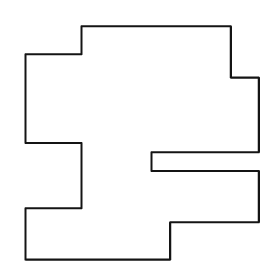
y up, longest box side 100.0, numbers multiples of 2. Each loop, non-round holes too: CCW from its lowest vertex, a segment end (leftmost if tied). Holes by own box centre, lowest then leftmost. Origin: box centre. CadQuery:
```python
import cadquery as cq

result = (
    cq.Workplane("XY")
    .moveTo(-50.0, -50.0)
    .lineTo(12.0, -50.0)
    .lineTo(12.0, -34.0)
    .lineTo(50.0, -34.0)
    .lineTo(50.0, -12.0)
    .lineTo(4.0, -12.0)
    .lineTo(4.0, -4.0)
    .lineTo(50.0, -4.0)
    .lineTo(50.0, 28.0)
    .lineTo(38.0, 28.0)
    .lineTo(38.0, 50.0)
    .lineTo(-26.0, 50.0)
    .lineTo(-26.0, 38.0)
    .lineTo(-50.0, 38.0)
    .lineTo(-50.0, 0.0)
    .lineTo(-26.0, 0.0)
    .lineTo(-26.0, -28.0)
    .lineTo(-50.0, -28.0)
    .close()
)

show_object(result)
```